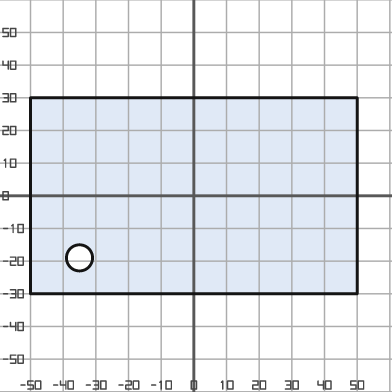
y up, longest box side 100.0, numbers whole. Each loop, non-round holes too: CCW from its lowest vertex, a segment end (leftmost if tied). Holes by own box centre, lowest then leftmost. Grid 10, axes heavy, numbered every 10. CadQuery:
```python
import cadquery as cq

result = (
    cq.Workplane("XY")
    .moveTo(-50.0, -30.0)
    .lineTo(50.0, -30.0)
    .lineTo(50.0, 30.0)
    .lineTo(-50.0, 30.0)
    .close()
    .moveTo(-35.0, -19.0)
    .circle(4.0)
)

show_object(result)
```